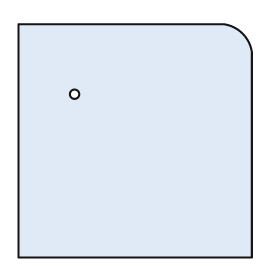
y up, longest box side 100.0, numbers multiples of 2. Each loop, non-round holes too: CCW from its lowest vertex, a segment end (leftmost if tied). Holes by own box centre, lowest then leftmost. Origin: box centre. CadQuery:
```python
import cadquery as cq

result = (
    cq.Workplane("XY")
    .moveTo(-50.0, -50.0)
    .lineTo(50.0, -50.0)
    .lineTo(50.0, 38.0)
    .threePointArc((46.0, 46.0), (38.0, 50.0))
    .lineTo(-50.0, 50.0)
    .close()
    .moveTo(-26.0, 20.0)
    .circle(2.0)
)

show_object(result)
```